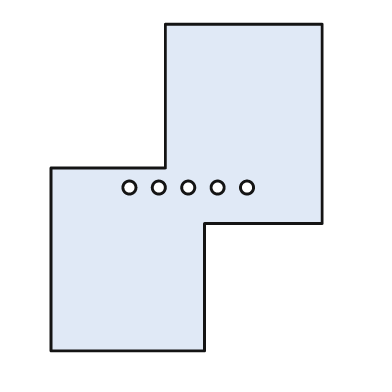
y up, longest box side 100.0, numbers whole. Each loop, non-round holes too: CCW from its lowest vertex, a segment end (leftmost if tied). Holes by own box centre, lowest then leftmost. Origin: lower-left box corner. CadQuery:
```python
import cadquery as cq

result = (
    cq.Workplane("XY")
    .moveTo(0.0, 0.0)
    .lineTo(47.0, 0.0)
    .lineTo(47.0, 39.0)
    .lineTo(83.0, 39.0)
    .lineTo(83.0, 100.0)
    .lineTo(35.0, 100.0)
    .lineTo(35.0, 56.0)
    .lineTo(0.0, 56.0)
    .close()
    .moveTo(24.0, 50.0)
    .circle(2.0)
    .moveTo(33.0, 50.0)
    .circle(2.0)
    .moveTo(42.0, 50.0)
    .circle(2.0)
    .moveTo(51.0, 50.0)
    .circle(2.0)
    .moveTo(60.0, 50.0)
    .circle(2.0)
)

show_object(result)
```